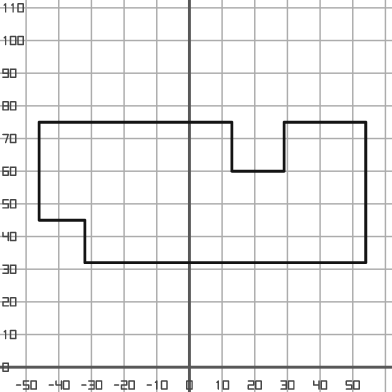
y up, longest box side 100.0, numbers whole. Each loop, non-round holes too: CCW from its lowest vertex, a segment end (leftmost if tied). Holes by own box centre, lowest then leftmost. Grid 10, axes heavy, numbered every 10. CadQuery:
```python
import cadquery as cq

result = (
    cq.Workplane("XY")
    .moveTo(-32.0, 32.0)
    .lineTo(54.0, 32.0)
    .lineTo(54.0, 75.0)
    .lineTo(29.0, 75.0)
    .lineTo(29.0, 60.0)
    .lineTo(13.0, 60.0)
    .lineTo(13.0, 75.0)
    .lineTo(-46.0, 75.0)
    .lineTo(-46.0, 45.0)
    .lineTo(-32.0, 45.0)
    .close()
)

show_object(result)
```